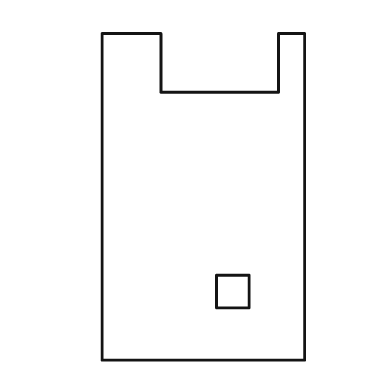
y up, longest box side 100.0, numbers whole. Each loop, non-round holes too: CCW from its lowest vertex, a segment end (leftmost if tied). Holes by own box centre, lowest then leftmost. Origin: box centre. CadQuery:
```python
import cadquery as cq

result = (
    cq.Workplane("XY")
    .moveTo(-31.0, -50.0)
    .lineTo(31.0, -50.0)
    .lineTo(31.0, 50.0)
    .lineTo(23.0, 50.0)
    .lineTo(23.0, 32.0)
    .lineTo(-13.0, 32.0)
    .lineTo(-13.0, 50.0)
    .lineTo(-31.0, 50.0)
    .close()
    .moveTo(4.0, -34.0)
    .lineTo(14.0, -34.0)
    .lineTo(14.0, -24.0)
    .lineTo(4.0, -24.0)
    .close()
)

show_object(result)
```